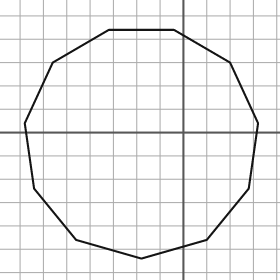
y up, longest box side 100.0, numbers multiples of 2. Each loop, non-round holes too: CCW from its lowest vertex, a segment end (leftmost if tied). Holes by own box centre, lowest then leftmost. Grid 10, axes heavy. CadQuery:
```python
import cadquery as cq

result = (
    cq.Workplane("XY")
    .moveTo(-18.0, -54.0)
    .lineTo(10.0, -46.0)
    .lineTo(28.0, -24.0)
    .lineTo(32.0, 4.0)
    .lineTo(20.0, 30.0)
    .lineTo(-4.0, 44.0)
    .lineTo(-32.0, 44.0)
    .lineTo(-56.0, 30.0)
    .lineTo(-68.0, 4.0)
    .lineTo(-64.0, -24.0)
    .lineTo(-46.0, -46.0)
    .close()
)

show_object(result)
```